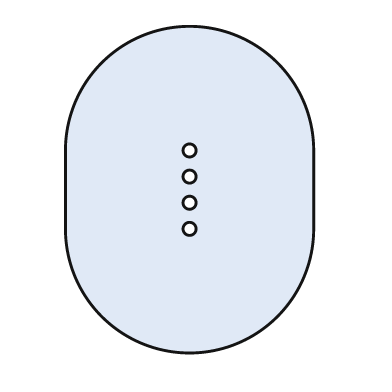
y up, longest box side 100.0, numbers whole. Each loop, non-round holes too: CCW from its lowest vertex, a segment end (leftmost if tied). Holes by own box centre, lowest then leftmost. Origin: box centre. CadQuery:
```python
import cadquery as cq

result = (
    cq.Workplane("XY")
    .moveTo(-38.0, -12.0)
    .threePointArc((0.0, -50.0), (38.0, -12.0))
    .lineTo(38.0, 12.0)
    .threePointArc((0.0, 50.0), (-38.0, 12.0))
    .close()
    .moveTo(0.0, -12.0)
    .circle(2.0)
    .moveTo(0.0, -4.0)
    .circle(2.0)
    .moveTo(0.0, 4.0)
    .circle(2.0)
    .moveTo(0.0, 12.0)
    .circle(2.0)
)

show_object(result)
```